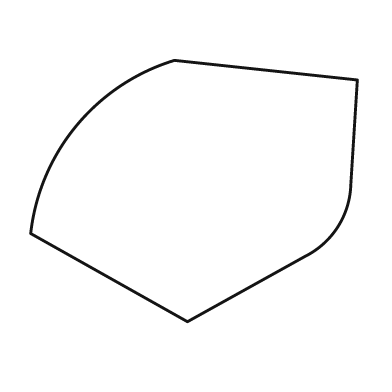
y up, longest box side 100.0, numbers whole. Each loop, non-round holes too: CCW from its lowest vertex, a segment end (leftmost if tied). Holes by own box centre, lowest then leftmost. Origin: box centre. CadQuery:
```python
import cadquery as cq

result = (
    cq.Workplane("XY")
    .moveTo(-2.0, -40.0)
    .lineTo(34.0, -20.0)
    .threePointArc((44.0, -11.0), (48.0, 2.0))
    .lineTo(50.0, 34.0)
    .lineTo(-6.0, 40.0)
    .threePointArc((-36.0, 20.0), (-50.0, -13.0))
    .close()
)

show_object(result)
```